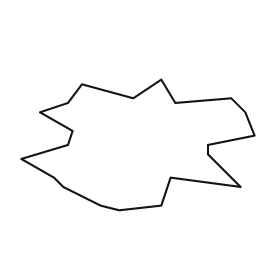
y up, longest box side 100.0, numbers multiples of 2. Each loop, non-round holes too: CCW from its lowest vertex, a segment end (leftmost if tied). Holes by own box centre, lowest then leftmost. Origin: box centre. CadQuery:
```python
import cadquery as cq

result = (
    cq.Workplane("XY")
    .moveTo(-8.0, -28.0)
    .lineTo(10.0, -26.0)
    .lineTo(14.0, -14.0)
    .lineTo(44.0, -18.0)
    .lineTo(30.0, -4.0)
    .lineTo(30.0, 0.0)
    .lineTo(50.0, 4.0)
    .lineTo(46.0, 14.0)
    .lineTo(40.0, 20.0)
    .lineTo(16.0, 18.0)
    .lineTo(10.0, 28.0)
    .lineTo(-2.0, 20.0)
    .lineTo(-24.0, 26.0)
    .lineTo(-30.0, 18.0)
    .lineTo(-42.0, 14.0)
    .lineTo(-28.0, 6.0)
    .lineTo(-30.0, 0.0)
    .lineTo(-50.0, -6.0)
    .lineTo(-36.0, -14.0)
    .lineTo(-32.0, -18.0)
    .lineTo(-16.0, -26.0)
    .close()
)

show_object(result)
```